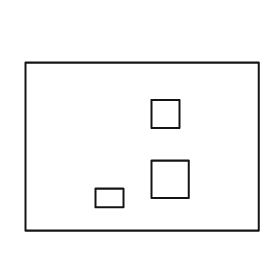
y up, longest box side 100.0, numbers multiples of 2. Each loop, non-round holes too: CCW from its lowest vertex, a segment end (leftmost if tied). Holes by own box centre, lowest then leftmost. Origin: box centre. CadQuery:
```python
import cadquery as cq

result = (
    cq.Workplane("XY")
    .moveTo(-50.0, -36.0)
    .lineTo(50.0, -36.0)
    .lineTo(50.0, 36.0)
    .lineTo(-50.0, 36.0)
    .close()
    .moveTo(-20.0, -26.0)
    .lineTo(-8.0, -26.0)
    .lineTo(-8.0, -18.0)
    .lineTo(-20.0, -18.0)
    .close()
    .moveTo(4.0, -22.0)
    .lineTo(20.0, -22.0)
    .lineTo(20.0, -6.0)
    .lineTo(4.0, -6.0)
    .close()
    .moveTo(4.0, 8.0)
    .lineTo(16.0, 8.0)
    .lineTo(16.0, 20.0)
    .lineTo(4.0, 20.0)
    .close()
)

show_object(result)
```